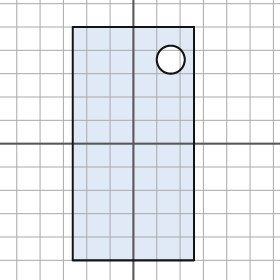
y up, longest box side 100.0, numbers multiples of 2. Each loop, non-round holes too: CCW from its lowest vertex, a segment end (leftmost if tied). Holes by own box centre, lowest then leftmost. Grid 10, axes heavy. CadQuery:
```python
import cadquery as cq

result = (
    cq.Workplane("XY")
    .moveTo(-26.0, -50.0)
    .lineTo(26.0, -50.0)
    .lineTo(26.0, 50.0)
    .lineTo(-26.0, 50.0)
    .close()
    .moveTo(16.0, 36.0)
    .circle(6.0)
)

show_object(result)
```